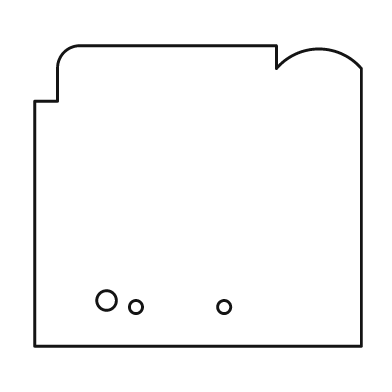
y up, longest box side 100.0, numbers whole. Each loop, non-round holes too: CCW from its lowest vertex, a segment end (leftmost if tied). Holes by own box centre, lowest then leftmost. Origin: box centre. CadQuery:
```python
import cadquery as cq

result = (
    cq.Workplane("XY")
    .moveTo(-50.0, -46.0)
    .lineTo(50.0, -46.0)
    .lineTo(50.0, 39.0)
    .threePointArc((37.0, 45.0), (24.0, 39.0))
    .lineTo(24.0, 46.0)
    .lineTo(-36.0, 46.0)
    .threePointArc((-41.0, 44.0), (-43.0, 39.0))
    .lineTo(-43.0, 29.0)
    .lineTo(-50.0, 29.0)
    .close()
    .moveTo(-19.0, -34.0)
    .circle(2.0)
    .moveTo(8.0, -34.0)
    .circle(2.0)
    .moveTo(-28.0, -32.0)
    .circle(3.0)
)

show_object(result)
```